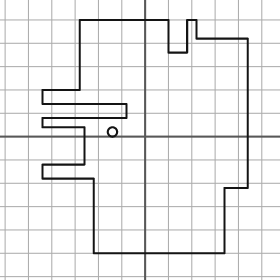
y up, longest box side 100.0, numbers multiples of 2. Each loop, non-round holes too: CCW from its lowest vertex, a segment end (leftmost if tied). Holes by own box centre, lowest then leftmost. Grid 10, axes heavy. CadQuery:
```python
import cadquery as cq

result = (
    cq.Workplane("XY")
    .moveTo(-22.0, -50.0)
    .lineTo(34.0, -50.0)
    .lineTo(34.0, -22.0)
    .lineTo(44.0, -22.0)
    .lineTo(44.0, 42.0)
    .lineTo(22.0, 42.0)
    .lineTo(22.0, 50.0)
    .lineTo(18.0, 50.0)
    .lineTo(18.0, 36.0)
    .lineTo(10.0, 36.0)
    .lineTo(10.0, 50.0)
    .lineTo(-28.0, 50.0)
    .lineTo(-28.0, 20.0)
    .lineTo(-44.0, 20.0)
    .lineTo(-44.0, 14.0)
    .lineTo(-8.0, 14.0)
    .lineTo(-8.0, 8.0)
    .lineTo(-44.0, 8.0)
    .lineTo(-44.0, 4.0)
    .lineTo(-26.0, 4.0)
    .lineTo(-26.0, -12.0)
    .lineTo(-44.0, -12.0)
    .lineTo(-44.0, -18.0)
    .lineTo(-22.0, -18.0)
    .close()
    .moveTo(-14.0, 2.0)
    .circle(2.0)
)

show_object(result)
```